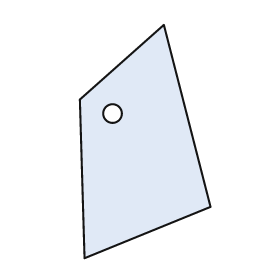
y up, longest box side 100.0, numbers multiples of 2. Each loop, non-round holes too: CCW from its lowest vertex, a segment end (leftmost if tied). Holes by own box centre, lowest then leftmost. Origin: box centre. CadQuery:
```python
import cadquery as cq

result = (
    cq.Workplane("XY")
    .moveTo(-26.0, -50.0)
    .lineTo(28.0, -28.0)
    .lineTo(8.0, 50.0)
    .lineTo(-28.0, 18.0)
    .close()
    .moveTo(-14.0, 12.0)
    .circle(4.0)
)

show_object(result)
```